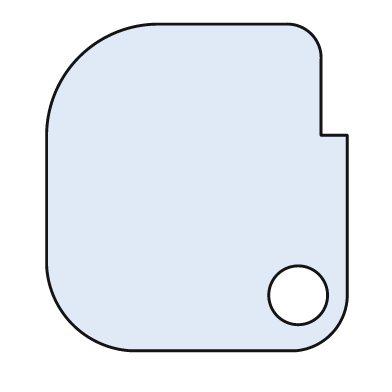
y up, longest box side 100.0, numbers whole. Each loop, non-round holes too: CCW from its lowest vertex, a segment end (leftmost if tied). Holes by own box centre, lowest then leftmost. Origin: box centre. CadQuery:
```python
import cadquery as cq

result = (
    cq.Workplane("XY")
    .moveTo(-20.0, -50.0)
    .lineTo(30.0, -50.0)
    .threePointArc((41.0, -45.0), (46.0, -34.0))
    .lineTo(46.0, 16.0)
    .lineTo(38.0, 16.0)
    .lineTo(38.0, 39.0)
    .threePointArc((35.0, 47.0), (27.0, 50.0))
    .lineTo(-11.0, 50.0)
    .threePointArc((-36.0, 40.0), (-46.0, 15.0))
    .lineTo(-46.0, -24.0)
    .threePointArc((-38.0, -42.0), (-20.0, -50.0))
    .close()
    .moveTo(31.0, -33.0)
    .circle(9.0)
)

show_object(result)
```